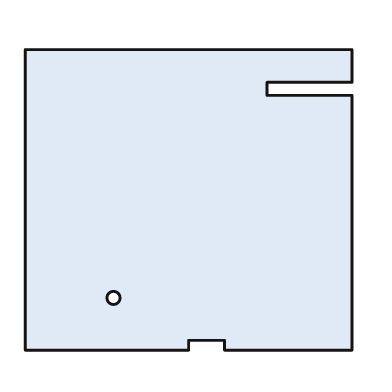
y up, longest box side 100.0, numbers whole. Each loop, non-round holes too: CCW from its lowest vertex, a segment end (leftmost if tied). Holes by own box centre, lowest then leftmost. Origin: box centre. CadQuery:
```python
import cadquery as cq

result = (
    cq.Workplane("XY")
    .moveTo(-50.0, -46.0)
    .lineTo(0.0, -46.0)
    .lineTo(0.0, -43.0)
    .lineTo(11.0, -43.0)
    .lineTo(11.0, -46.0)
    .lineTo(50.0, -46.0)
    .lineTo(50.0, 32.0)
    .lineTo(24.0, 32.0)
    .lineTo(24.0, 36.0)
    .lineTo(50.0, 36.0)
    .lineTo(50.0, 46.0)
    .lineTo(-50.0, 46.0)
    .close()
    .moveTo(-23.0, -30.0)
    .circle(2.0)
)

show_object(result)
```